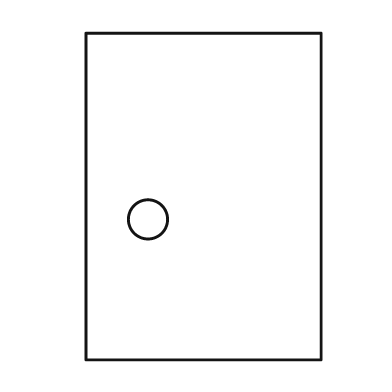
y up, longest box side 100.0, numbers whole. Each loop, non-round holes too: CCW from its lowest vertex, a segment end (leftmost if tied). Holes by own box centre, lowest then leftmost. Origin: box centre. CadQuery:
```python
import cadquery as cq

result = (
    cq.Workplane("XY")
    .moveTo(-36.0, -50.0)
    .lineTo(36.0, -50.0)
    .lineTo(36.0, 50.0)
    .lineTo(-36.0, 50.0)
    .close()
    .moveTo(-17.0, -7.0)
    .circle(6.0)
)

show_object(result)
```